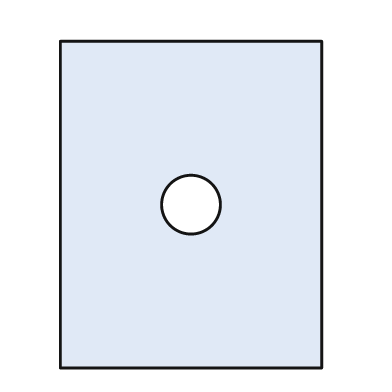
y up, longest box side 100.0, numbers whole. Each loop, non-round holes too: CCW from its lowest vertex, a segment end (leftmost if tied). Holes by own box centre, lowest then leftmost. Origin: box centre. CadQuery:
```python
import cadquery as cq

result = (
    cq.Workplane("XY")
    .moveTo(-40.0, -50.0)
    .lineTo(40.0, -50.0)
    .lineTo(40.0, 50.0)
    .lineTo(-40.0, 50.0)
    .close()
    .moveTo(0.0, 0.0)
    .circle(9.0)
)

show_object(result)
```